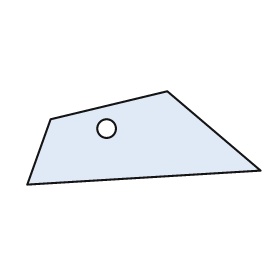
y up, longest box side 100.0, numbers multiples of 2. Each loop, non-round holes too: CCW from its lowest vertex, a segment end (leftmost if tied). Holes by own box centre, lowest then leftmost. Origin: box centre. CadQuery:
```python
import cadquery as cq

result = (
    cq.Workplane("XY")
    .moveTo(-50.0, -20.0)
    .lineTo(50.0, -14.0)
    .lineTo(10.0, 20.0)
    .lineTo(-40.0, 8.0)
    .close()
    .moveTo(-16.0, 4.0)
    .circle(4.0)
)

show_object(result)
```